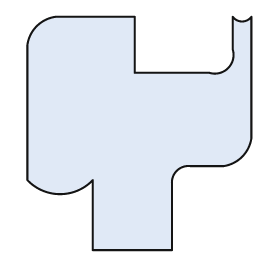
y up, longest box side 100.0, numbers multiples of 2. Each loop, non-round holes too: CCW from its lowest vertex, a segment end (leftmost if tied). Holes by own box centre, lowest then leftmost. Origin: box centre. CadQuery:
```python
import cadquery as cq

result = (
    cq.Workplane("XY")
    .moveTo(-20.0, -50.0)
    .lineTo(14.0, -50.0)
    .lineTo(14.0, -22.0)
    .threePointArc((16.0, -16.0), (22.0, -14.0))
    .lineTo(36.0, -14.0)
    .threePointArc((44.0, -10.0), (48.0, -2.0))
    .lineTo(48.0, 50.0)
    .threePointArc((44.0, 48.0), (40.0, 50.0))
    .lineTo(40.0, 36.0)
    .threePointArc((38.0, 28.0), (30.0, 26.0))
    .lineTo(-2.0, 26.0)
    .lineTo(-2.0, 50.0)
    .lineTo(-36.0, 50.0)
    .threePointArc((-44.0, 46.0), (-48.0, 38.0))
    .lineTo(-48.0, -20.0)
    .threePointArc((-34.0, -26.0), (-20.0, -20.0))
    .close()
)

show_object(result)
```